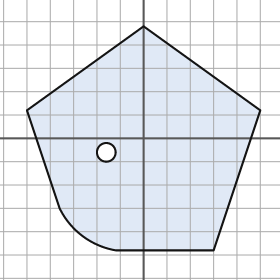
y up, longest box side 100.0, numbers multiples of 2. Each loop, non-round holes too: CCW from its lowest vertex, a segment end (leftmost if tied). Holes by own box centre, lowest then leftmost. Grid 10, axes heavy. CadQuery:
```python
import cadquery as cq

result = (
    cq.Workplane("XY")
    .moveTo(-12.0, -48.0)
    .lineTo(30.0, -48.0)
    .lineTo(50.0, 12.0)
    .lineTo(0.0, 48.0)
    .lineTo(-50.0, 12.0)
    .lineTo(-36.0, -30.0)
    .threePointArc((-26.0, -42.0), (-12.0, -48.0))
    .close()
    .moveTo(-16.0, -6.0)
    .circle(4.0)
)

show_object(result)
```